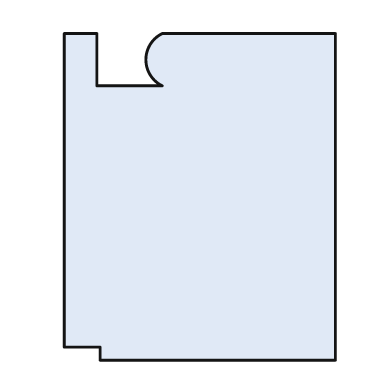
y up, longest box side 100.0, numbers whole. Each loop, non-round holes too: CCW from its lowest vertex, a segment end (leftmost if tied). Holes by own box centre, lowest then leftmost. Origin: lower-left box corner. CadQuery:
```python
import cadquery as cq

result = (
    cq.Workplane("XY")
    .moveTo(11.0, 0.0)
    .lineTo(83.0, 0.0)
    .lineTo(83.0, 100.0)
    .lineTo(30.0, 100.0)
    .threePointArc((25.0, 92.0), (30.0, 84.0))
    .lineTo(10.0, 84.0)
    .lineTo(10.0, 100.0)
    .lineTo(0.0, 100.0)
    .lineTo(0.0, 4.0)
    .lineTo(11.0, 4.0)
    .close()
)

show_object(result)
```